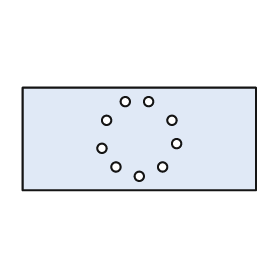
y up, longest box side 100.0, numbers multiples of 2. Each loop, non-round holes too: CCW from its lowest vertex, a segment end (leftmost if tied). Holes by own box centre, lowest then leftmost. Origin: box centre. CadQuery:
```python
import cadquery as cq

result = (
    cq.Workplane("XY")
    .moveTo(-50.0, -22.0)
    .lineTo(50.0, -22.0)
    .lineTo(50.0, 22.0)
    .lineTo(-50.0, 22.0)
    .close()
    .moveTo(0.0, -16.0)
    .circle(2.0)
    .moveTo(-10.0, -12.0)
    .circle(2.0)
    .moveTo(10.0, -12.0)
    .circle(2.0)
    .moveTo(-16.0, -4.0)
    .circle(2.0)
    .moveTo(16.0, -2.0)
    .circle(2.0)
    .moveTo(-14.0, 8.0)
    .circle(2.0)
    .moveTo(14.0, 8.0)
    .circle(2.0)
    .moveTo(-6.0, 16.0)
    .circle(2.0)
    .moveTo(4.0, 16.0)
    .circle(2.0)
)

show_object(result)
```